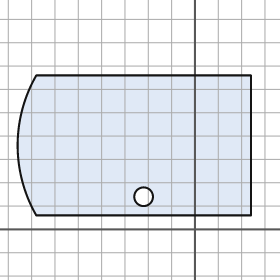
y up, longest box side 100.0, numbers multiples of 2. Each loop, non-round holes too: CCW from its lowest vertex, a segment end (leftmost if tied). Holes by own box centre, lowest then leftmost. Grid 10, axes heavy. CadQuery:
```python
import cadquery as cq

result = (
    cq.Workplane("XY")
    .moveTo(-68.0, 6.0)
    .lineTo(24.0, 6.0)
    .lineTo(24.0, 66.0)
    .lineTo(-68.0, 66.0)
    .threePointArc((-76.0, 36.0), (-68.0, 6.0))
    .close()
    .moveTo(-22.0, 14.0)
    .circle(4.0)
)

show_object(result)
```